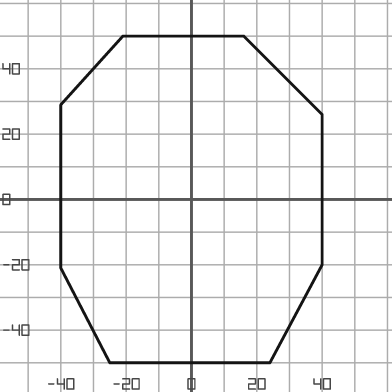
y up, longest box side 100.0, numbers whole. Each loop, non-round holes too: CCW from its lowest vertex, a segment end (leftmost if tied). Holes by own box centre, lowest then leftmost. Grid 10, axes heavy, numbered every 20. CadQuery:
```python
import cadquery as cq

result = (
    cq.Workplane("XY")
    .moveTo(-25.0, -50.0)
    .lineTo(24.0, -50.0)
    .lineTo(40.0, -20.0)
    .lineTo(40.0, 26.0)
    .lineTo(16.0, 50.0)
    .lineTo(-21.0, 50.0)
    .lineTo(-40.0, 29.0)
    .lineTo(-40.0, -21.0)
    .close()
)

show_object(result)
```